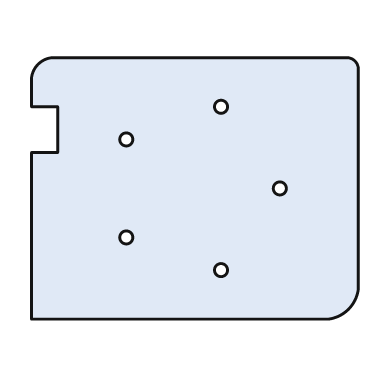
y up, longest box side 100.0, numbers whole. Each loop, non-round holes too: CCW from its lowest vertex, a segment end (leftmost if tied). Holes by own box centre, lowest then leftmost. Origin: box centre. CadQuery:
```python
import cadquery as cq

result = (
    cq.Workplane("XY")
    .moveTo(-50.0, -40.0)
    .lineTo(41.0, -40.0)
    .threePointArc((47.0, -37.0), (50.0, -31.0))
    .lineTo(50.0, 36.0)
    .threePointArc((49.0, 39.0), (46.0, 40.0))
    .lineTo(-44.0, 40.0)
    .threePointArc((-48.0, 38.0), (-50.0, 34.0))
    .lineTo(-50.0, 25.0)
    .lineTo(-42.0, 25.0)
    .lineTo(-42.0, 11.0)
    .lineTo(-50.0, 11.0)
    .close()
    .moveTo(8.0, -25.0)
    .circle(2.0)
    .moveTo(-21.0, -15.0)
    .circle(2.0)
    .moveTo(26.0, 0.0)
    .circle(2.0)
    .moveTo(-21.0, 15.0)
    .circle(2.0)
    .moveTo(8.0, 25.0)
    .circle(2.0)
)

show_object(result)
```